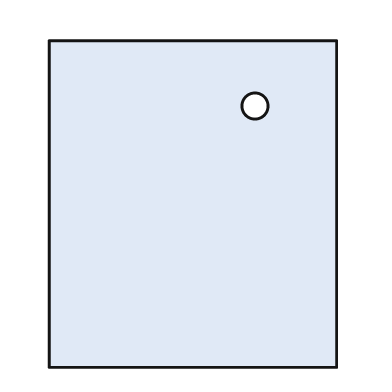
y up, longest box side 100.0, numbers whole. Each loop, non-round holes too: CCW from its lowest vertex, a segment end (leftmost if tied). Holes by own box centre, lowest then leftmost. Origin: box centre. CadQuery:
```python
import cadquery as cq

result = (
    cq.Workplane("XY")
    .moveTo(-44.0, -50.0)
    .lineTo(44.0, -50.0)
    .lineTo(44.0, 50.0)
    .lineTo(-44.0, 50.0)
    .close()
    .moveTo(19.0, 30.0)
    .circle(4.0)
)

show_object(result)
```